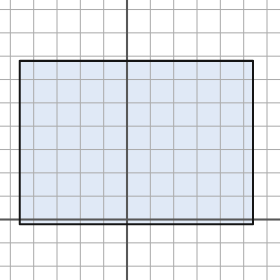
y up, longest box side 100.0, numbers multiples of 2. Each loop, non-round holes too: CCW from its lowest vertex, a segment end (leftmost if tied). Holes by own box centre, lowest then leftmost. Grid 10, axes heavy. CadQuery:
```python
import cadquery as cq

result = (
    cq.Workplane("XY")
    .moveTo(-46.0, -2.0)
    .lineTo(54.0, -2.0)
    .lineTo(54.0, 68.0)
    .lineTo(-46.0, 68.0)
    .close()
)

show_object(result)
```